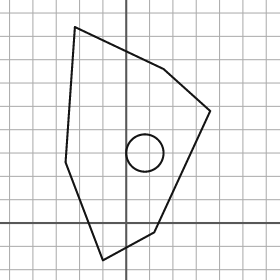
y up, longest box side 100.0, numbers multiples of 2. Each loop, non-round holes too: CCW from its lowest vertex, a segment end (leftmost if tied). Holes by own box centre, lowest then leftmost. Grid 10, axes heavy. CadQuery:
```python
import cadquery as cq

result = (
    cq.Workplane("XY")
    .moveTo(-10.0, -16.0)
    .lineTo(12.0, -4.0)
    .lineTo(36.0, 48.0)
    .lineTo(16.0, 66.0)
    .lineTo(-22.0, 84.0)
    .lineTo(-26.0, 26.0)
    .close()
    .moveTo(8.0, 30.0)
    .circle(8.0)
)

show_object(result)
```